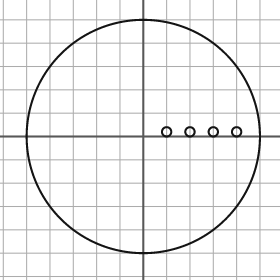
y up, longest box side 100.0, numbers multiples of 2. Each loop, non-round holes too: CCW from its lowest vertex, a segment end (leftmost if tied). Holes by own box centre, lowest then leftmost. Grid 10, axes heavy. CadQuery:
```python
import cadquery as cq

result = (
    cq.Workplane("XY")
    .moveTo(0.0, 0.0)
    .circle(50.0)
    .moveTo(10.0, 2.0)
    .circle(2.0)
    .moveTo(20.0, 2.0)
    .circle(2.0)
    .moveTo(30.0, 2.0)
    .circle(2.0)
    .moveTo(40.0, 2.0)
    .circle(2.0)
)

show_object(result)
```